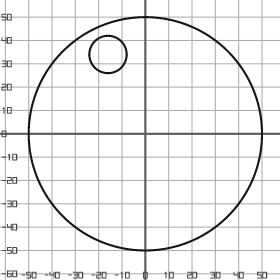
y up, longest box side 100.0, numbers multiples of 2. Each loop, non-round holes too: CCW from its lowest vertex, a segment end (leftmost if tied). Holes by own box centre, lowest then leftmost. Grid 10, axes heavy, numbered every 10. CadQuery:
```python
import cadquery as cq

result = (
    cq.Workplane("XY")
    .moveTo(0.0, 0.0)
    .circle(50.0)
    .moveTo(-16.0, 34.0)
    .circle(8.0)
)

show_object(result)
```